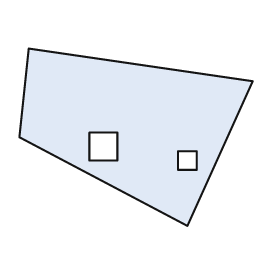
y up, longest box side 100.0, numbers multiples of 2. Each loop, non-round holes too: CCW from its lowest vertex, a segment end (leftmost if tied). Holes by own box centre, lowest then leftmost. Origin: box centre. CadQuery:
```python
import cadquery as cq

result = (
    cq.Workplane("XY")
    .moveTo(22.0, -38.0)
    .lineTo(50.0, 24.0)
    .lineTo(-46.0, 38.0)
    .lineTo(-50.0, 0.0)
    .close()
    .moveTo(18.0, -14.0)
    .lineTo(26.0, -14.0)
    .lineTo(26.0, -6.0)
    .lineTo(18.0, -6.0)
    .close()
    .moveTo(-20.0, -10.0)
    .lineTo(-8.0, -10.0)
    .lineTo(-8.0, 2.0)
    .lineTo(-20.0, 2.0)
    .close()
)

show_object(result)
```